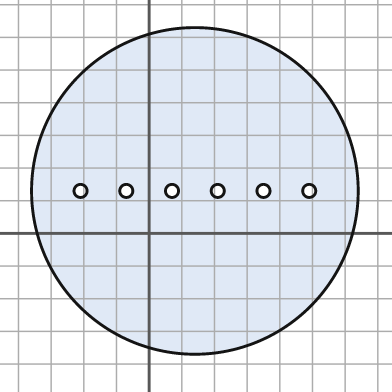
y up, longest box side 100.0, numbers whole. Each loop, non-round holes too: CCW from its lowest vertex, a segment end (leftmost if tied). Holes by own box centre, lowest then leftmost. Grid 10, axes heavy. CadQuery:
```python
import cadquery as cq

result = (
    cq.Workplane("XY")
    .moveTo(14.0, 13.0)
    .circle(50.0)
    .moveTo(-21.0, 13.0)
    .circle(2.0)
    .moveTo(-7.0, 13.0)
    .circle(2.0)
    .moveTo(7.0, 13.0)
    .circle(2.0)
    .moveTo(21.0, 13.0)
    .circle(2.0)
    .moveTo(35.0, 13.0)
    .circle(2.0)
    .moveTo(49.0, 13.0)
    .circle(2.0)
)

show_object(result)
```